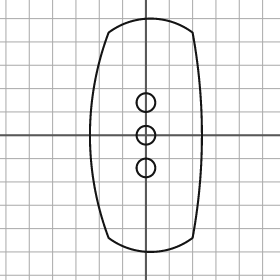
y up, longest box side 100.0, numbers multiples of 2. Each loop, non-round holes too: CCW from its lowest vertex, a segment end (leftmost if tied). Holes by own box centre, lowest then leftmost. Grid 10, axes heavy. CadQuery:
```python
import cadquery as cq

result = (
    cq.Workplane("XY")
    .moveTo(-16.0, -44.0)
    .threePointArc((2.0, -50.0), (20.0, -44.0))
    .threePointArc((24.0, 0.0), (20.0, 44.0))
    .threePointArc((2.0, 50.0), (-16.0, 44.0))
    .threePointArc((-24.0, 0.0), (-16.0, -44.0))
    .close()
    .moveTo(0.0, -14.0)
    .circle(4.0)
    .moveTo(0.0, 0.0)
    .circle(4.0)
    .moveTo(0.0, 14.0)
    .circle(4.0)
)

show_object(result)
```